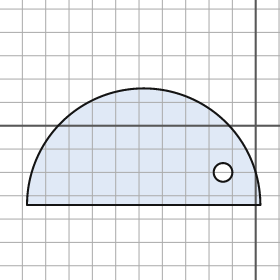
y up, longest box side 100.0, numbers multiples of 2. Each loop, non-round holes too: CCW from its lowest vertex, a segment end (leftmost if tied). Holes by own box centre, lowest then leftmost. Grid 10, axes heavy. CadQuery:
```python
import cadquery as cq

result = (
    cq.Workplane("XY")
    .moveTo(-98.0, -34.0)
    .lineTo(2.0, -34.0)
    .threePointArc((-48.0, 16.0), (-98.0, -34.0))
    .close()
    .moveTo(-14.0, -20.0)
    .circle(4.0)
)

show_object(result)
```